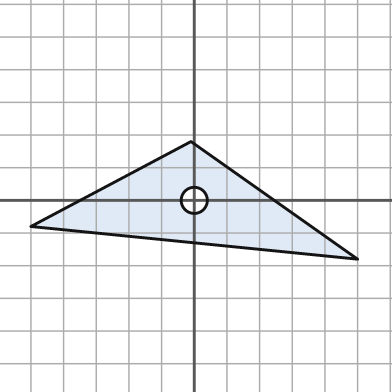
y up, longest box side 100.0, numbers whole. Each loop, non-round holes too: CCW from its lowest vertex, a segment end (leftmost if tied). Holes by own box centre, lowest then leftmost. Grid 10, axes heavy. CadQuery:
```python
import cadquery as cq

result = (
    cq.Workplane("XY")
    .moveTo(50.0, -18.0)
    .lineTo(-1.0, 18.0)
    .lineTo(-50.0, -8.0)
    .close()
    .moveTo(0.0, 0.0)
    .circle(4.0)
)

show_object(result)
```